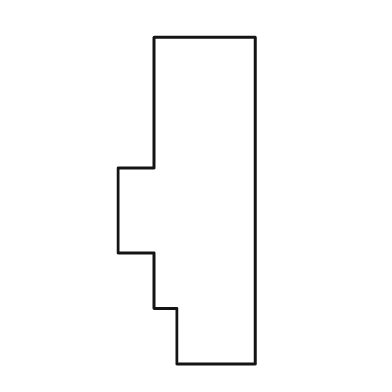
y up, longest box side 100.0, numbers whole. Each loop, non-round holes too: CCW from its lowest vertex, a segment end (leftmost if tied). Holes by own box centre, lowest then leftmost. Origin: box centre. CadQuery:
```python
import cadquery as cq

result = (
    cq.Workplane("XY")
    .moveTo(-3.0, -50.0)
    .lineTo(21.0, -50.0)
    .lineTo(21.0, 50.0)
    .lineTo(-10.0, 50.0)
    .lineTo(-10.0, 10.0)
    .lineTo(-21.0, 10.0)
    .lineTo(-21.0, -16.0)
    .lineTo(-10.0, -16.0)
    .lineTo(-10.0, -33.0)
    .lineTo(-3.0, -33.0)
    .close()
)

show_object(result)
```